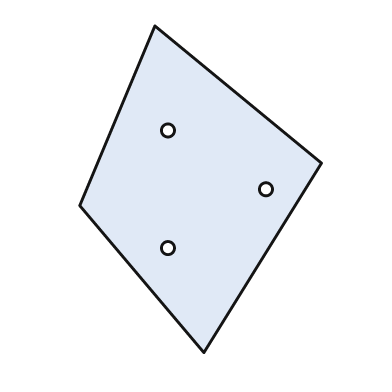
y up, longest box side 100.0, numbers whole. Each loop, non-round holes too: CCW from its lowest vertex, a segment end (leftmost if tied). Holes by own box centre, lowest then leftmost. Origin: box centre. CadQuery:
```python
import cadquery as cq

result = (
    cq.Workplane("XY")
    .moveTo(1.0, -50.0)
    .lineTo(37.0, 8.0)
    .lineTo(-14.0, 50.0)
    .lineTo(-37.0, -5.0)
    .close()
    .moveTo(-10.0, -18.0)
    .circle(2.0)
    .moveTo(20.0, 0.0)
    .circle(2.0)
    .moveTo(-10.0, 18.0)
    .circle(2.0)
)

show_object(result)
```